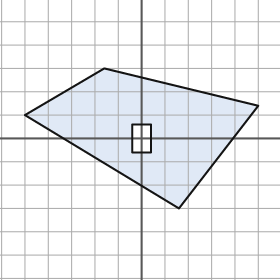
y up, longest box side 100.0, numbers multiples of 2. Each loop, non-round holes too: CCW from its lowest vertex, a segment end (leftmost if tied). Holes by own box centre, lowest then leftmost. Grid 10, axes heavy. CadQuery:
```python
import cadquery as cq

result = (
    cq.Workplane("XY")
    .moveTo(16.0, -30.0)
    .lineTo(50.0, 14.0)
    .lineTo(-16.0, 30.0)
    .lineTo(-50.0, 10.0)
    .close()
    .moveTo(-4.0, -6.0)
    .lineTo(4.0, -6.0)
    .lineTo(4.0, 6.0)
    .lineTo(-4.0, 6.0)
    .close()
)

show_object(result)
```